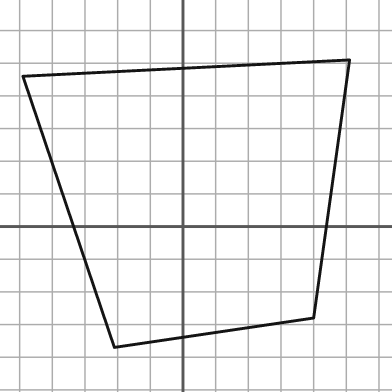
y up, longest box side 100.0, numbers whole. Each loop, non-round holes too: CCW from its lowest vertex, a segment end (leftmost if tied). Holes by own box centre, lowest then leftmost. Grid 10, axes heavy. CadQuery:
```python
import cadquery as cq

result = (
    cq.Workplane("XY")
    .moveTo(-21.0, -37.0)
    .lineTo(40.0, -28.0)
    .lineTo(51.0, 51.0)
    .lineTo(-49.0, 46.0)
    .close()
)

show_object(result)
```